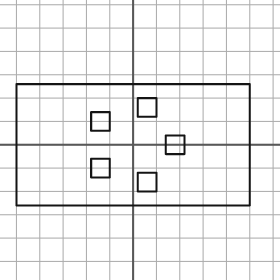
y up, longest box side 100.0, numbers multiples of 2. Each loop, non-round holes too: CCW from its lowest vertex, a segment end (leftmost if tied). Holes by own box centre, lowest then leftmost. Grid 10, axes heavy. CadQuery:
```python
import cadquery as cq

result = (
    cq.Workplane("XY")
    .moveTo(-50.0, -26.0)
    .lineTo(50.0, -26.0)
    .lineTo(50.0, 26.0)
    .lineTo(-50.0, 26.0)
    .close()
    .moveTo(2.0, -20.0)
    .lineTo(10.0, -20.0)
    .lineTo(10.0, -12.0)
    .lineTo(2.0, -12.0)
    .close()
    .moveTo(-18.0, -14.0)
    .lineTo(-10.0, -14.0)
    .lineTo(-10.0, -6.0)
    .lineTo(-18.0, -6.0)
    .close()
    .moveTo(14.0, -4.0)
    .lineTo(22.0, -4.0)
    .lineTo(22.0, 4.0)
    .lineTo(14.0, 4.0)
    .close()
    .moveTo(-18.0, 6.0)
    .lineTo(-10.0, 6.0)
    .lineTo(-10.0, 14.0)
    .lineTo(-18.0, 14.0)
    .close()
    .moveTo(2.0, 12.0)
    .lineTo(10.0, 12.0)
    .lineTo(10.0, 20.0)
    .lineTo(2.0, 20.0)
    .close()
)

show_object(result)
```